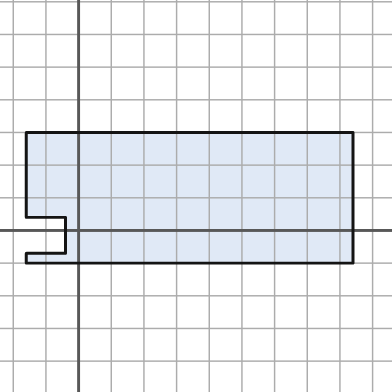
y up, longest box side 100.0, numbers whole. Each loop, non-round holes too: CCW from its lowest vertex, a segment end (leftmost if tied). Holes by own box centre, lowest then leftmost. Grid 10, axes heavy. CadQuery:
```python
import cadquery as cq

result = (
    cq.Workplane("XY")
    .moveTo(-16.0, -10.0)
    .lineTo(84.0, -10.0)
    .lineTo(84.0, 30.0)
    .lineTo(-16.0, 30.0)
    .lineTo(-16.0, 4.0)
    .lineTo(-4.0, 4.0)
    .lineTo(-4.0, -7.0)
    .lineTo(-16.0, -7.0)
    .close()
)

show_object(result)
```